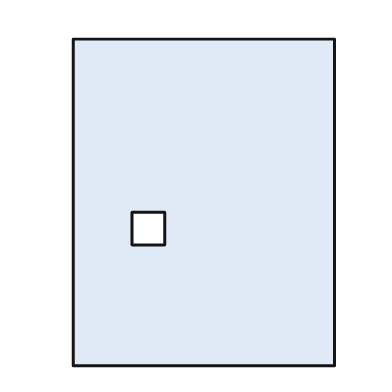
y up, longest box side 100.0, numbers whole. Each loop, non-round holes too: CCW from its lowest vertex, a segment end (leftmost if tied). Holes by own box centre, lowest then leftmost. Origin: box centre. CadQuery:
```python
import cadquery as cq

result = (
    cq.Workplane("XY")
    .moveTo(-40.0, -50.0)
    .lineTo(40.0, -50.0)
    .lineTo(40.0, 50.0)
    .lineTo(-40.0, 50.0)
    .close()
    .moveTo(-22.0, -13.0)
    .lineTo(-12.0, -13.0)
    .lineTo(-12.0, -3.0)
    .lineTo(-22.0, -3.0)
    .close()
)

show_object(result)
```